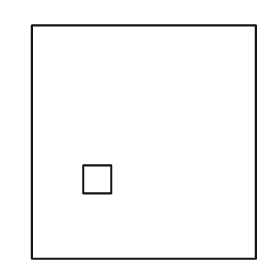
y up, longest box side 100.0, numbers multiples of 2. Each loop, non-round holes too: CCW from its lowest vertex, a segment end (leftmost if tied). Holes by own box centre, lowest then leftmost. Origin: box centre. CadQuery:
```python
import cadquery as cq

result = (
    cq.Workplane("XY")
    .moveTo(-48.0, -50.0)
    .lineTo(48.0, -50.0)
    .lineTo(48.0, 50.0)
    .lineTo(-48.0, 50.0)
    .close()
    .moveTo(-26.0, -22.0)
    .lineTo(-14.0, -22.0)
    .lineTo(-14.0, -10.0)
    .lineTo(-26.0, -10.0)
    .close()
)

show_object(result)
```